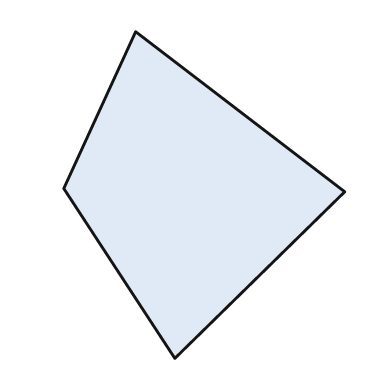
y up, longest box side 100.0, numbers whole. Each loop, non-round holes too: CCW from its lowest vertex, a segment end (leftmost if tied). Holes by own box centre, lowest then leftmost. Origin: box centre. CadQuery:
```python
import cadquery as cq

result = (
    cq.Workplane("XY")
    .moveTo(-9.0, -50.0)
    .lineTo(43.0, 1.0)
    .lineTo(-21.0, 50.0)
    .lineTo(-43.0, 2.0)
    .close()
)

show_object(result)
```